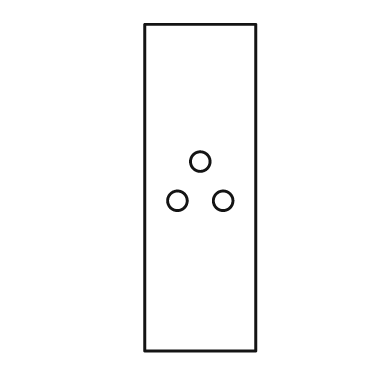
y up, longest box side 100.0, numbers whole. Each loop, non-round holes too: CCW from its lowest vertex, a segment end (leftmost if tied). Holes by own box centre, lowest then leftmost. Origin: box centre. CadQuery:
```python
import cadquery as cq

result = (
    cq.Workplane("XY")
    .moveTo(-17.0, -50.0)
    .lineTo(17.0, -50.0)
    .lineTo(17.0, 50.0)
    .lineTo(-17.0, 50.0)
    .close()
    .moveTo(-7.0, -4.0)
    .circle(3.0)
    .moveTo(7.0, -4.0)
    .circle(3.0)
    .moveTo(0.0, 8.0)
    .circle(3.0)
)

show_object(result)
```